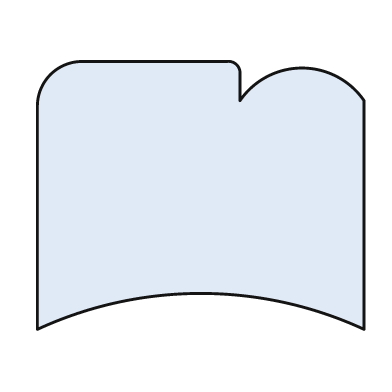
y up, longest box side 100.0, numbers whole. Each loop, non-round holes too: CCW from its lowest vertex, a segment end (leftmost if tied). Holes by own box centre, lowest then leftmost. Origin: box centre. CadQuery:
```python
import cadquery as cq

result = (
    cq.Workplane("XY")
    .moveTo(-50.0, -41.0)
    .threePointArc((0.0, -30.0), (50.0, -41.0))
    .lineTo(50.0, 29.0)
    .threePointArc((31.0, 39.0), (12.0, 29.0))
    .lineTo(12.0, 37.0)
    .threePointArc((11.0, 40.0), (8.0, 41.0))
    .lineTo(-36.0, 41.0)
    .threePointArc((-46.0, 37.0), (-50.0, 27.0))
    .close()
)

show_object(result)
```